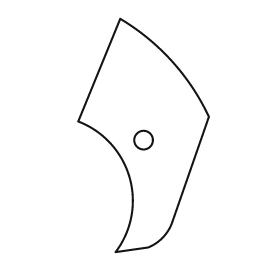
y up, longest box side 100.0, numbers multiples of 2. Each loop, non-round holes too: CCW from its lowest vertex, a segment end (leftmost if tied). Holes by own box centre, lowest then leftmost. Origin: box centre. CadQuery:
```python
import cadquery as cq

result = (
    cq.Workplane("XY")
    .moveTo(-12.0, -50.0)
    .lineTo(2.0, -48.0)
    .threePointArc((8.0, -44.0), (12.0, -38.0))
    .lineTo(28.0, 8.0)
    .threePointArc((12.0, 32.0), (-10.0, 50.0))
    .lineTo(-28.0, 6.0)
    .threePointArc((-6.0, -18.0), (-12.0, -50.0))
    .close()
    .moveTo(0.0, -2.0)
    .circle(4.0)
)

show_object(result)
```